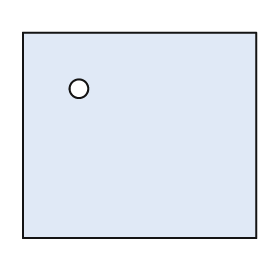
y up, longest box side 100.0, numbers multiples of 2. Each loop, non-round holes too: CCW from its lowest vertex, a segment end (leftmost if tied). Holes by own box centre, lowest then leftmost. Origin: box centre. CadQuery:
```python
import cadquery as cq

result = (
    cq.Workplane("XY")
    .moveTo(-50.0, -44.0)
    .lineTo(50.0, -44.0)
    .lineTo(50.0, 44.0)
    .lineTo(-50.0, 44.0)
    .close()
    .moveTo(-26.0, 20.0)
    .circle(4.0)
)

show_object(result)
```